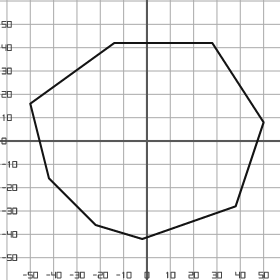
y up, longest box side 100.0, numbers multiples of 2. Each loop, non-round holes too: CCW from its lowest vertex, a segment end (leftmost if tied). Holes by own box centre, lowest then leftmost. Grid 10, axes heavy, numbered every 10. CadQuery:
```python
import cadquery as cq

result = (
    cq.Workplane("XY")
    .moveTo(-2.0, -42.0)
    .lineTo(38.0, -28.0)
    .lineTo(50.0, 8.0)
    .lineTo(28.0, 42.0)
    .lineTo(-14.0, 42.0)
    .lineTo(-50.0, 16.0)
    .lineTo(-42.0, -16.0)
    .lineTo(-22.0, -36.0)
    .close()
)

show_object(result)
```